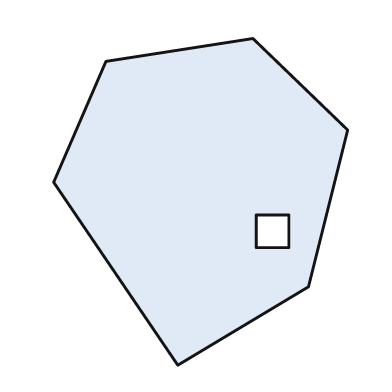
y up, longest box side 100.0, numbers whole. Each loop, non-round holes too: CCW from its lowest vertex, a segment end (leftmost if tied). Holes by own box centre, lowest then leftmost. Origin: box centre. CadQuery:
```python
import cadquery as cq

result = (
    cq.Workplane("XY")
    .moveTo(-7.0, -50.0)
    .lineTo(33.0, -26.0)
    .lineTo(45.0, 22.0)
    .lineTo(16.0, 50.0)
    .lineTo(-29.0, 43.0)
    .lineTo(-45.0, 6.0)
    .close()
    .moveTo(17.0, -14.0)
    .lineTo(27.0, -14.0)
    .lineTo(27.0, -4.0)
    .lineTo(17.0, -4.0)
    .close()
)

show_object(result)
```